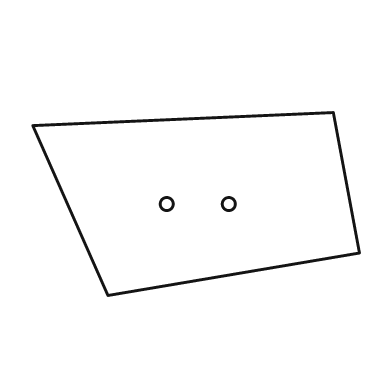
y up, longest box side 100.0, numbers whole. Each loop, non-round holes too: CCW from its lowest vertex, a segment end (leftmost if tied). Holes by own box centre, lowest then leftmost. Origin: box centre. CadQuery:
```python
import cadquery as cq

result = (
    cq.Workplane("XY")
    .moveTo(-27.0, -28.0)
    .lineTo(50.0, -15.0)
    .lineTo(42.0, 28.0)
    .lineTo(-50.0, 24.0)
    .close()
    .moveTo(-9.0, 0.0)
    .circle(2.0)
    .moveTo(10.0, 0.0)
    .circle(2.0)
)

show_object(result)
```